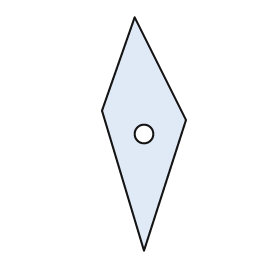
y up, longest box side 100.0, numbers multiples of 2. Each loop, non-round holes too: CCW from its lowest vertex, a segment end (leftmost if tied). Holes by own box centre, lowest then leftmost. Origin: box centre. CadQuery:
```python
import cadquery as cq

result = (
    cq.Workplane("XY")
    .moveTo(0.0, -50.0)
    .lineTo(18.0, 6.0)
    .lineTo(-4.0, 50.0)
    .lineTo(-18.0, 10.0)
    .close()
    .moveTo(0.0, 0.0)
    .circle(4.0)
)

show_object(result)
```